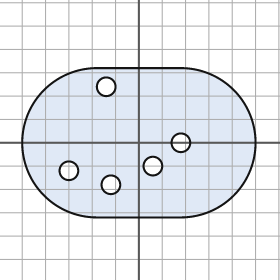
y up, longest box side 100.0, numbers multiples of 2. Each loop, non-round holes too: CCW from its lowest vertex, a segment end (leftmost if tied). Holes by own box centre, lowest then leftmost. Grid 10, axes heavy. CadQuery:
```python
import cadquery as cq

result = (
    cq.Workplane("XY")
    .moveTo(-18.0, -32.0)
    .lineTo(18.0, -32.0)
    .threePointArc((50.0, 0.0), (18.0, 32.0))
    .lineTo(-18.0, 32.0)
    .threePointArc((-50.0, 0.0), (-18.0, -32.0))
    .close()
    .moveTo(-12.0, -18.0)
    .circle(4.0)
    .moveTo(-30.0, -12.0)
    .circle(4.0)
    .moveTo(6.0, -10.0)
    .circle(4.0)
    .moveTo(18.0, 0.0)
    .circle(4.0)
    .moveTo(-14.0, 24.0)
    .circle(4.0)
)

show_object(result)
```